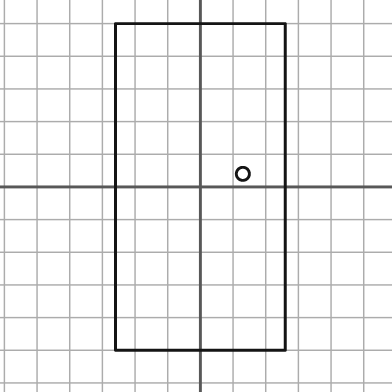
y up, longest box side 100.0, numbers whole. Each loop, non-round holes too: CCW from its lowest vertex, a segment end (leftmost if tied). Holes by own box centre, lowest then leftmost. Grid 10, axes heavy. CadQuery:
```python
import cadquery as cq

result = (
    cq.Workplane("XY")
    .moveTo(-26.0, -50.0)
    .lineTo(26.0, -50.0)
    .lineTo(26.0, 50.0)
    .lineTo(-26.0, 50.0)
    .close()
    .moveTo(13.0, 4.0)
    .circle(2.0)
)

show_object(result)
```